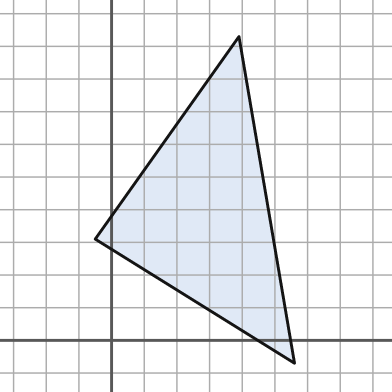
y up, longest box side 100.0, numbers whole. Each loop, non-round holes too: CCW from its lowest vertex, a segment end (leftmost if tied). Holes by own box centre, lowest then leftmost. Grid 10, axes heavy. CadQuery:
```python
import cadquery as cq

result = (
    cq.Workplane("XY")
    .moveTo(56.0, -7.0)
    .lineTo(39.0, 93.0)
    .lineTo(-5.0, 31.0)
    .close()
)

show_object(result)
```